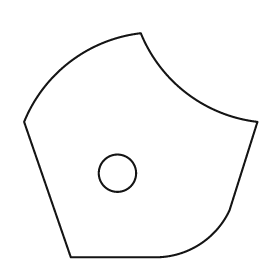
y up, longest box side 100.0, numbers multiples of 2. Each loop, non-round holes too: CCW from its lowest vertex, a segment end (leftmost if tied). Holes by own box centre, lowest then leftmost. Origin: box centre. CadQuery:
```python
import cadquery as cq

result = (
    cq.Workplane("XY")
    .moveTo(-30.0, -48.0)
    .lineTo(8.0, -48.0)
    .threePointArc((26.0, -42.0), (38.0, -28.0))
    .lineTo(50.0, 10.0)
    .threePointArc((20.0, 22.0), (0.0, 48.0))
    .threePointArc((-30.0, 36.0), (-50.0, 10.0))
    .close()
    .moveTo(-10.0, -12.0)
    .circle(8.0)
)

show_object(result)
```